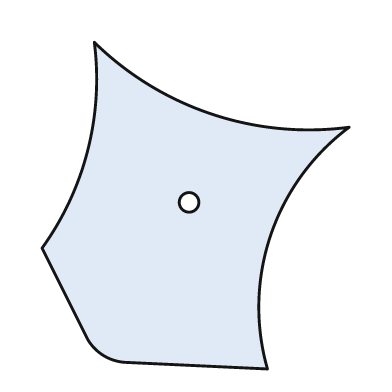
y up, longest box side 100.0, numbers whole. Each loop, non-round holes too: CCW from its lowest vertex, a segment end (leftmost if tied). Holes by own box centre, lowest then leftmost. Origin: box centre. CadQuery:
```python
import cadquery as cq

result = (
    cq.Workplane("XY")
    .moveTo(22.0, -50.0)
    .threePointArc((23.0, -9.0), (47.0, 24.0))
    .threePointArc((5.0, 28.0), (-31.0, 50.0))
    .threePointArc((-33.0, 17.0), (-47.0, -13.0))
    .lineTo(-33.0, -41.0)
    .threePointArc((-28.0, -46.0), (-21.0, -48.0))
    .close()
    .moveTo(-2.0, 1.0)
    .circle(3.0)
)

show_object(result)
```